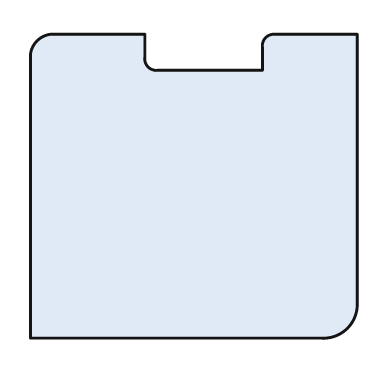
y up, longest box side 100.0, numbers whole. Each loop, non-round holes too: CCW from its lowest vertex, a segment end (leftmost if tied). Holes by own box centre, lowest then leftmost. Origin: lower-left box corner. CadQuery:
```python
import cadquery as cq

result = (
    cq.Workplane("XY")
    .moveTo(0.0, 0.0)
    .lineTo(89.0, 0.0)
    .threePointArc((97.0, 3.0), (100.0, 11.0))
    .lineTo(100.0, 93.0)
    .lineTo(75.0, 93.0)
    .threePointArc((72.0, 92.0), (71.0, 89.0))
    .lineTo(71.0, 82.0)
    .lineTo(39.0, 82.0)
    .threePointArc((36.0, 83.0), (35.0, 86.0))
    .lineTo(35.0, 93.0)
    .lineTo(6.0, 93.0)
    .threePointArc((2.0, 91.0), (0.0, 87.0))
    .close()
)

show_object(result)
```